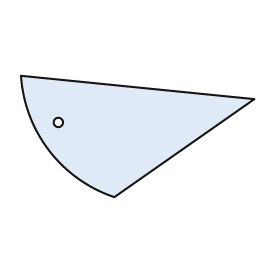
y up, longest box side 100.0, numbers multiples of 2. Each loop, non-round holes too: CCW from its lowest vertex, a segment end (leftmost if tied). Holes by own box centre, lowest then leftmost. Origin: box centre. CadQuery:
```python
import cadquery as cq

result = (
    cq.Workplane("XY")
    .moveTo(-10.0, -26.0)
    .lineTo(50.0, 16.0)
    .lineTo(-50.0, 26.0)
    .threePointArc((-38.0, -6.0), (-10.0, -26.0))
    .close()
    .moveTo(-34.0, 6.0)
    .circle(2.0)
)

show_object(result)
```